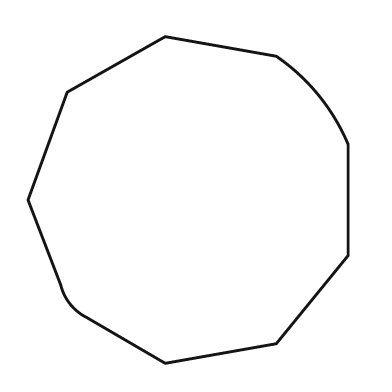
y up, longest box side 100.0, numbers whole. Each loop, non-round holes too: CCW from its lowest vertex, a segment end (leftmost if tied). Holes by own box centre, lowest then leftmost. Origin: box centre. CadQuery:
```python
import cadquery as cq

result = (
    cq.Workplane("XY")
    .moveTo(-7.0, -50.0)
    .lineTo(27.0, -44.0)
    .lineTo(49.0, -17.0)
    .lineTo(49.0, 17.0)
    .threePointArc((40.0, 32.0), (27.0, 44.0))
    .lineTo(-7.0, 50.0)
    .lineTo(-37.0, 33.0)
    .lineTo(-49.0, 0.0)
    .lineTo(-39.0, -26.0)
    .threePointArc((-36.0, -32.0), (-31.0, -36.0))
    .close()
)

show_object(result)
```